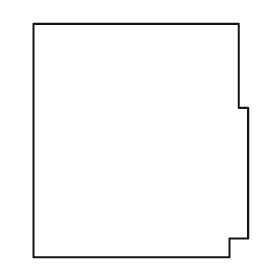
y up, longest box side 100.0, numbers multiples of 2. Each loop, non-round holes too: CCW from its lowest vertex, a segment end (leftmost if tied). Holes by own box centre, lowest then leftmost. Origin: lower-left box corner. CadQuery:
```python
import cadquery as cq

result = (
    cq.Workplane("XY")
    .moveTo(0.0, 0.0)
    .lineTo(84.0, 0.0)
    .lineTo(84.0, 8.0)
    .lineTo(92.0, 8.0)
    .lineTo(92.0, 64.0)
    .lineTo(88.0, 64.0)
    .lineTo(88.0, 100.0)
    .lineTo(0.0, 100.0)
    .close()
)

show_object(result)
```